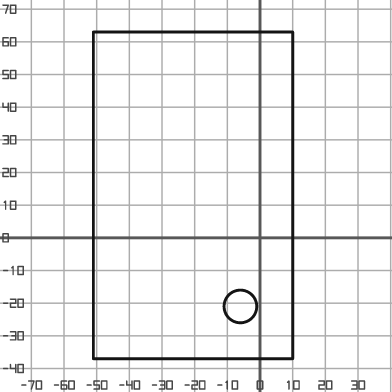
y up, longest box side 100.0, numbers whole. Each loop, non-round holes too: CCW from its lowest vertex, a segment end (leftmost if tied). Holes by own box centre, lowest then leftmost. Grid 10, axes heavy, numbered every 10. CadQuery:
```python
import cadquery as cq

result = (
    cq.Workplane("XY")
    .moveTo(-51.0, -37.0)
    .lineTo(10.0, -37.0)
    .lineTo(10.0, 63.0)
    .lineTo(-51.0, 63.0)
    .close()
    .moveTo(-6.0, -21.0)
    .circle(5.0)
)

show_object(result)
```